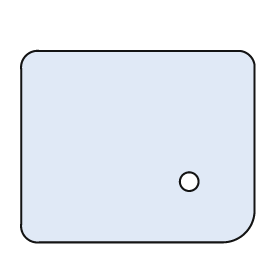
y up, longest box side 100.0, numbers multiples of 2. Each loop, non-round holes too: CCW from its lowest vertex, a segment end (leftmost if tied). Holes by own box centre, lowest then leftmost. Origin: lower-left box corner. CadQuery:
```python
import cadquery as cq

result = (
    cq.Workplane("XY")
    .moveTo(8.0, 0.0)
    .lineTo(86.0, 0.0)
    .threePointArc((96.0, 4.0), (100.0, 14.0))
    .lineTo(100.0, 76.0)
    .threePointArc((98.0, 80.0), (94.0, 82.0))
    .lineTo(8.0, 82.0)
    .threePointArc((2.0, 80.0), (0.0, 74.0))
    .lineTo(0.0, 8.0)
    .threePointArc((2.0, 2.0), (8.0, 0.0))
    .close()
    .moveTo(72.0, 26.0)
    .circle(4.0)
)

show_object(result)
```